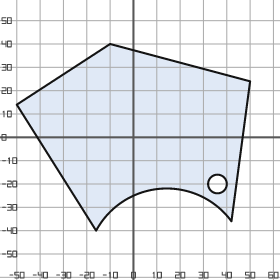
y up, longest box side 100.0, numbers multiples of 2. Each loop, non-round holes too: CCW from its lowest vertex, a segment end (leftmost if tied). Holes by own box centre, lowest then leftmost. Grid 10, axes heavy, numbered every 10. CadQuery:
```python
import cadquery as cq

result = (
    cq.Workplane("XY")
    .moveTo(-16.0, -40.0)
    .threePointArc((12.0, -22.0), (42.0, -36.0))
    .lineTo(50.0, 24.0)
    .lineTo(-10.0, 40.0)
    .lineTo(-50.0, 14.0)
    .close()
    .moveTo(36.0, -20.0)
    .circle(4.0)
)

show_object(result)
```